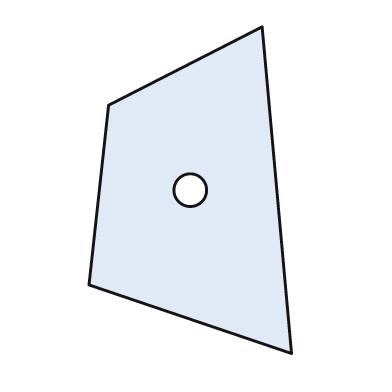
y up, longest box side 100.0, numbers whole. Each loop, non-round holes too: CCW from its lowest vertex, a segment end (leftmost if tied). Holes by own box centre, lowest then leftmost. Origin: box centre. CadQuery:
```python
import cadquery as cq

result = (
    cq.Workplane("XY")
    .moveTo(31.0, -50.0)
    .lineTo(22.0, 50.0)
    .lineTo(-25.0, 26.0)
    .lineTo(-31.0, -29.0)
    .close()
    .moveTo(0.0, 0.0)
    .circle(5.0)
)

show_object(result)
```